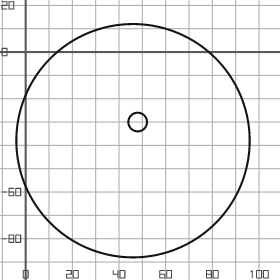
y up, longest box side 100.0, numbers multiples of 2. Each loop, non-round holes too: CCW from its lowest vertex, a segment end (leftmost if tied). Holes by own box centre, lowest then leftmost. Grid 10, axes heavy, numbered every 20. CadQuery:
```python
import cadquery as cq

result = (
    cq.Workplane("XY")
    .moveTo(46.0, -38.0)
    .circle(50.0)
    .moveTo(48.0, -30.0)
    .circle(4.0)
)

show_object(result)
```